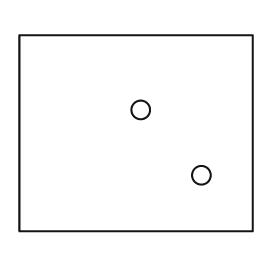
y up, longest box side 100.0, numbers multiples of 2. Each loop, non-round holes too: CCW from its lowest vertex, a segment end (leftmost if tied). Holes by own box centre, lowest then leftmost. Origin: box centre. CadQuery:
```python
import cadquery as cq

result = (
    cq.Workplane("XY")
    .moveTo(-50.0, -42.0)
    .lineTo(50.0, -42.0)
    .lineTo(50.0, 42.0)
    .lineTo(-50.0, 42.0)
    .close()
    .moveTo(28.0, -18.0)
    .circle(4.0)
    .moveTo(2.0, 10.0)
    .circle(4.0)
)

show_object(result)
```